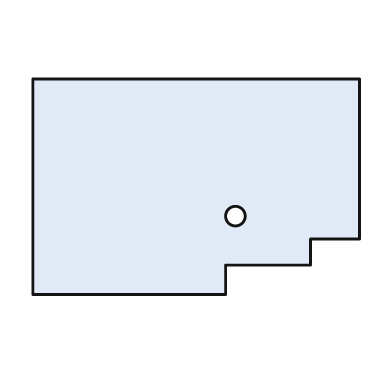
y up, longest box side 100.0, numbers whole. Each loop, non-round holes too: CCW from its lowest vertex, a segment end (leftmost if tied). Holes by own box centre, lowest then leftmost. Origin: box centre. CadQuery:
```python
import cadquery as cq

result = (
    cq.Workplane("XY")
    .moveTo(-50.0, -33.0)
    .lineTo(9.0, -33.0)
    .lineTo(9.0, -24.0)
    .lineTo(35.0, -24.0)
    .lineTo(35.0, -16.0)
    .lineTo(50.0, -16.0)
    .lineTo(50.0, 33.0)
    .lineTo(-50.0, 33.0)
    .close()
    .moveTo(12.0, -9.0)
    .circle(3.0)
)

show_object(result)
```